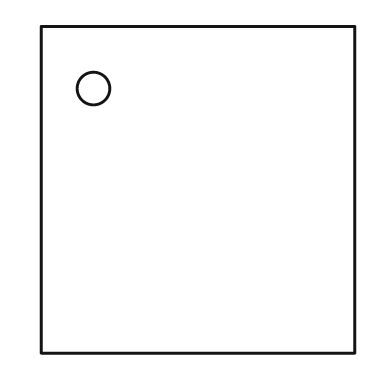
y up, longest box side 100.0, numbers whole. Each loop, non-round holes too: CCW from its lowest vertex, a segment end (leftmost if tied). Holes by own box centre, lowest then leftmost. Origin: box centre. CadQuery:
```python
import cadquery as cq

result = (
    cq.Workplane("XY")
    .moveTo(-48.0, -50.0)
    .lineTo(48.0, -50.0)
    .lineTo(48.0, 50.0)
    .lineTo(-48.0, 50.0)
    .close()
    .moveTo(-32.0, 31.0)
    .circle(5.0)
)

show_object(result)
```